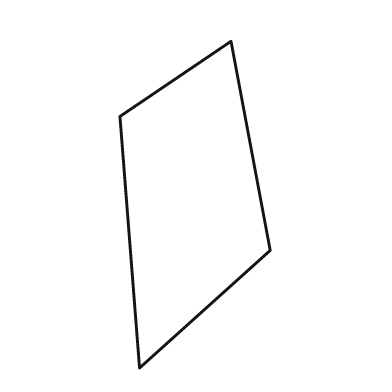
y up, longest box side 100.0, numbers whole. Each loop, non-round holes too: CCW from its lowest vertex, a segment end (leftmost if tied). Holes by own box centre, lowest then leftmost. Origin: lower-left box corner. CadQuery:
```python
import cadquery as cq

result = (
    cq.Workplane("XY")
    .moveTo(6.0, 0.0)
    .lineTo(46.0, 36.0)
    .lineTo(34.0, 100.0)
    .lineTo(0.0, 77.0)
    .close()
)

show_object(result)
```